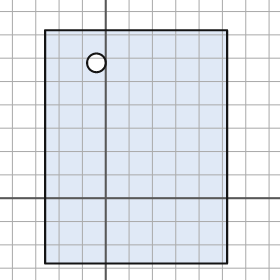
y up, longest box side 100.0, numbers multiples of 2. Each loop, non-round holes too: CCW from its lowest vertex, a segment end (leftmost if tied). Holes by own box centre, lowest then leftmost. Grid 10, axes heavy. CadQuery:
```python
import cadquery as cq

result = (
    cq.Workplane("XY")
    .moveTo(-26.0, -28.0)
    .lineTo(52.0, -28.0)
    .lineTo(52.0, 72.0)
    .lineTo(-26.0, 72.0)
    .close()
    .moveTo(-4.0, 58.0)
    .circle(4.0)
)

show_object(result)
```